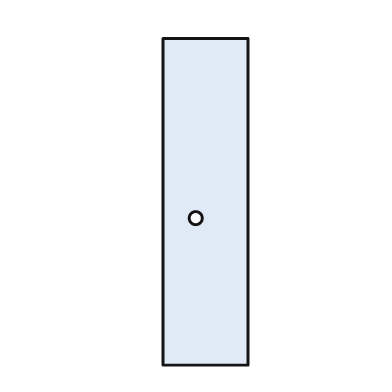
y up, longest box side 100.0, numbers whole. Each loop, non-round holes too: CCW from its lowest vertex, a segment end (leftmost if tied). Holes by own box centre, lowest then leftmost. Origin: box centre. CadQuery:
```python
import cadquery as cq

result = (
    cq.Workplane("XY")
    .moveTo(-13.0, -50.0)
    .lineTo(13.0, -50.0)
    .lineTo(13.0, 50.0)
    .lineTo(-13.0, 50.0)
    .close()
    .moveTo(-3.0, -5.0)
    .circle(2.0)
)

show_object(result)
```